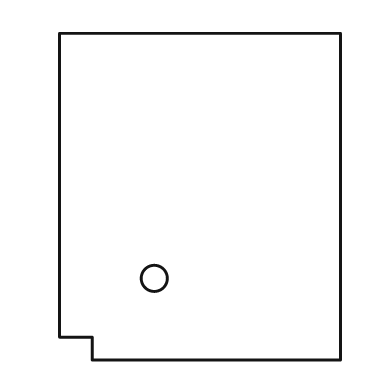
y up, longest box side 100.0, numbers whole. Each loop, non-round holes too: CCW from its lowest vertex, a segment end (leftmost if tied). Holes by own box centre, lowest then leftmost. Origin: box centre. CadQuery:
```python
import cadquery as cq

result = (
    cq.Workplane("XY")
    .moveTo(-33.0, -50.0)
    .lineTo(43.0, -50.0)
    .lineTo(43.0, 50.0)
    .lineTo(-43.0, 50.0)
    .lineTo(-43.0, -43.0)
    .lineTo(-33.0, -43.0)
    .close()
    .moveTo(-14.0, -25.0)
    .circle(4.0)
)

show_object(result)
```